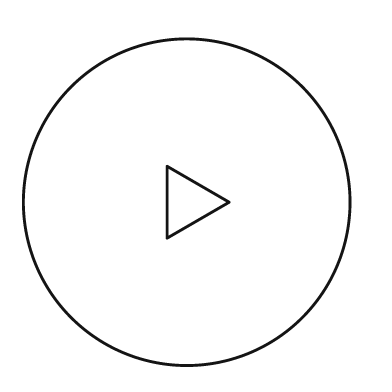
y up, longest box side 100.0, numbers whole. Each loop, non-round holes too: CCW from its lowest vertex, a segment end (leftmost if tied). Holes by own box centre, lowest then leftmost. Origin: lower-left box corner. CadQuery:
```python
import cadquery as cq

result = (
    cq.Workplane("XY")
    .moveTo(50.0, 50.0)
    .circle(50.0)
    .moveTo(44.0, 39.0)
    .lineTo(63.0, 50.0)
    .lineTo(44.0, 61.0)
    .close()
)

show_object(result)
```